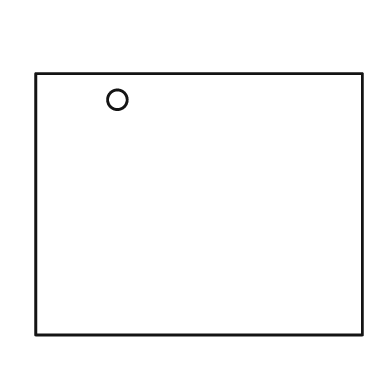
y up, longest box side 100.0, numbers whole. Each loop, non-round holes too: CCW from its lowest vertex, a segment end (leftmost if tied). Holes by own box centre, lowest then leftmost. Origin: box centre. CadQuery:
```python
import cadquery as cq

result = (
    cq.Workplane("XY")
    .moveTo(-50.0, -40.0)
    .lineTo(50.0, -40.0)
    .lineTo(50.0, 40.0)
    .lineTo(-50.0, 40.0)
    .close()
    .moveTo(-25.0, 32.0)
    .circle(3.0)
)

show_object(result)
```